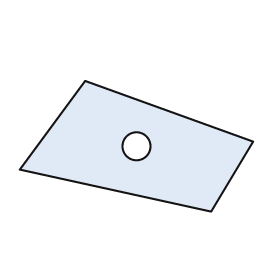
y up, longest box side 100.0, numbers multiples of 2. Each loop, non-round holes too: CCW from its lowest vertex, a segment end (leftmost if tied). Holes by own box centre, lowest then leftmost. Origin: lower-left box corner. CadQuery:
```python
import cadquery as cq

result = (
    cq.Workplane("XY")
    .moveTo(82.0, 0.0)
    .lineTo(100.0, 30.0)
    .lineTo(28.0, 56.0)
    .lineTo(0.0, 18.0)
    .close()
    .moveTo(50.0, 28.0)
    .circle(6.0)
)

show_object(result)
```